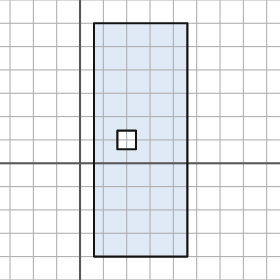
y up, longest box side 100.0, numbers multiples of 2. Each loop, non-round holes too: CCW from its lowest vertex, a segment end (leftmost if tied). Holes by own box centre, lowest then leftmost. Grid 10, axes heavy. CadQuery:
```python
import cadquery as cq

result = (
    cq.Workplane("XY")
    .moveTo(6.0, -40.0)
    .lineTo(46.0, -40.0)
    .lineTo(46.0, 60.0)
    .lineTo(6.0, 60.0)
    .close()
    .moveTo(16.0, 6.0)
    .lineTo(24.0, 6.0)
    .lineTo(24.0, 14.0)
    .lineTo(16.0, 14.0)
    .close()
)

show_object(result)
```